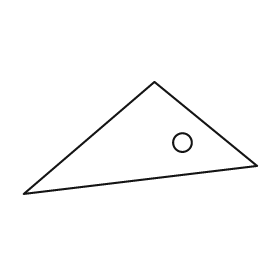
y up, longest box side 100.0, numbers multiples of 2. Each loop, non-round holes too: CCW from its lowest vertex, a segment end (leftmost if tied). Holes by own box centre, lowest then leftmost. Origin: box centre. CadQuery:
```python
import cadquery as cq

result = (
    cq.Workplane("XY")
    .moveTo(-50.0, -24.0)
    .lineTo(50.0, -12.0)
    .lineTo(6.0, 24.0)
    .close()
    .moveTo(18.0, -2.0)
    .circle(4.0)
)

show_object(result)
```